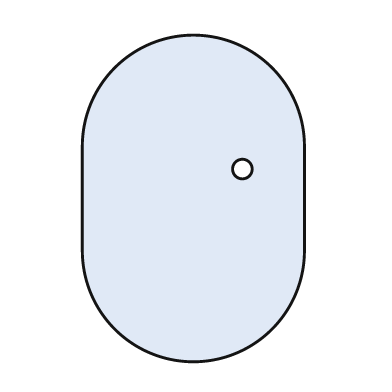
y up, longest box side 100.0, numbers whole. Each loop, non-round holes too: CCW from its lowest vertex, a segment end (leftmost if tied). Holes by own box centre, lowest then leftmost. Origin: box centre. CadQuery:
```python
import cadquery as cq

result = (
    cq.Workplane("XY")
    .moveTo(-34.0, -16.0)
    .threePointArc((0.0, -50.0), (34.0, -16.0))
    .lineTo(34.0, 16.0)
    .threePointArc((0.0, 50.0), (-34.0, 16.0))
    .close()
    .moveTo(15.0, 9.0)
    .circle(3.0)
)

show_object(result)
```